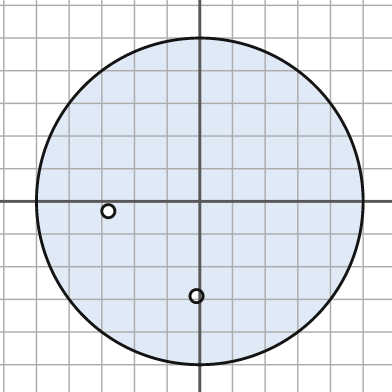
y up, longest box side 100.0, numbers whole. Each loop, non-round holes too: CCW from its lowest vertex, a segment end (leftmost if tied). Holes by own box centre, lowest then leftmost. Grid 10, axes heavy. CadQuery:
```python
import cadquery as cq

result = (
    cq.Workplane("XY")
    .moveTo(0.0, 0.0)
    .circle(50.0)
    .moveTo(-1.0, -29.0)
    .circle(2.0)
    .moveTo(-28.0, -3.0)
    .circle(2.0)
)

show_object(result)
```